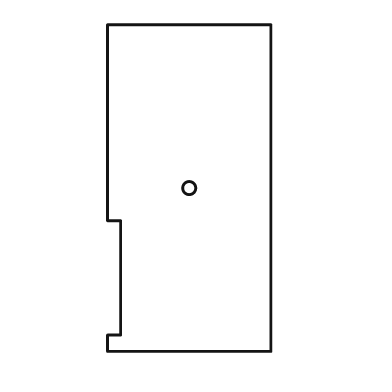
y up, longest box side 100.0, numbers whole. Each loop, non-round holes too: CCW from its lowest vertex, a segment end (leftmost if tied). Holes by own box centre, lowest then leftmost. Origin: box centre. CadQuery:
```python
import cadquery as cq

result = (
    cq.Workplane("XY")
    .moveTo(-25.0, -50.0)
    .lineTo(25.0, -50.0)
    .lineTo(25.0, 50.0)
    .lineTo(-25.0, 50.0)
    .lineTo(-25.0, -10.0)
    .lineTo(-21.0, -10.0)
    .lineTo(-21.0, -45.0)
    .lineTo(-25.0, -45.0)
    .close()
    .moveTo(0.0, 0.0)
    .circle(2.0)
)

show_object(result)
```